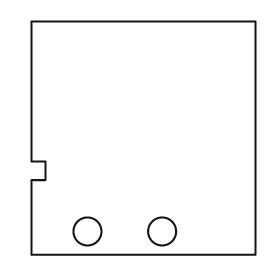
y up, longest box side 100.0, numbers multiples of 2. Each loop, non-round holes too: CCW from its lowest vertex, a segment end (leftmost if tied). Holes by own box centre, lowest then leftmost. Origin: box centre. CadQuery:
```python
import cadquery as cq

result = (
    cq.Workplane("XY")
    .moveTo(-48.0, -50.0)
    .lineTo(48.0, -50.0)
    .lineTo(48.0, 50.0)
    .lineTo(-48.0, 50.0)
    .lineTo(-48.0, -10.0)
    .lineTo(-42.0, -10.0)
    .lineTo(-42.0, -18.0)
    .lineTo(-48.0, -18.0)
    .close()
    .moveTo(-24.0, -40.0)
    .circle(6.0)
    .moveTo(8.0, -40.0)
    .circle(6.0)
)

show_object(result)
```